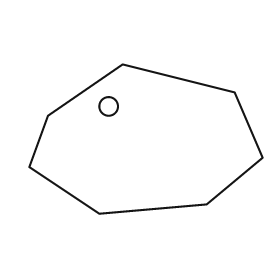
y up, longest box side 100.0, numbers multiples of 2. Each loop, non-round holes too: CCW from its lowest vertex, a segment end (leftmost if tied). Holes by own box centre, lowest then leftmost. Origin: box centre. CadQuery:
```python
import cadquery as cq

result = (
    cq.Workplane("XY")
    .moveTo(-20.0, -32.0)
    .lineTo(26.0, -28.0)
    .lineTo(50.0, -8.0)
    .lineTo(38.0, 20.0)
    .lineTo(-10.0, 32.0)
    .lineTo(-42.0, 10.0)
    .lineTo(-50.0, -12.0)
    .close()
    .moveTo(-16.0, 14.0)
    .circle(4.0)
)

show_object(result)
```